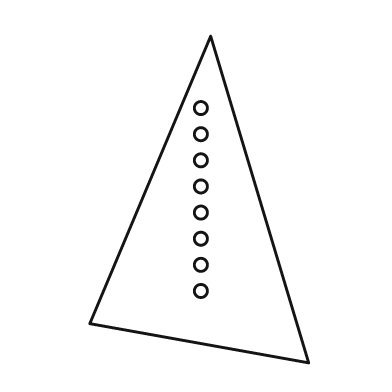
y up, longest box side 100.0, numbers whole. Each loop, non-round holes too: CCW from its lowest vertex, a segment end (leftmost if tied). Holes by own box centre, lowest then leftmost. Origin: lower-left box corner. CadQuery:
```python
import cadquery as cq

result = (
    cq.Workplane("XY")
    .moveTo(67.0, 0.0)
    .lineTo(37.0, 100.0)
    .lineTo(0.0, 12.0)
    .close()
    .moveTo(34.0, 22.0)
    .circle(2.0)
    .moveTo(34.0, 30.0)
    .circle(2.0)
    .moveTo(34.0, 38.0)
    .circle(2.0)
    .moveTo(34.0, 46.0)
    .circle(2.0)
    .moveTo(34.0, 54.0)
    .circle(2.0)
    .moveTo(34.0, 62.0)
    .circle(2.0)
    .moveTo(34.0, 70.0)
    .circle(2.0)
    .moveTo(34.0, 78.0)
    .circle(2.0)
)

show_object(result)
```